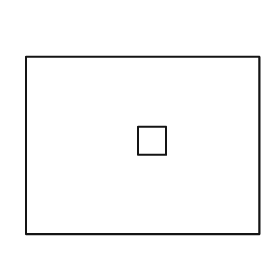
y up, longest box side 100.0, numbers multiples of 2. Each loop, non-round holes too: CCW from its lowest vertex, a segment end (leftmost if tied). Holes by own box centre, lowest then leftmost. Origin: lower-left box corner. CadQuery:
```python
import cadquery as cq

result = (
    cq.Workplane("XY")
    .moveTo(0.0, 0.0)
    .lineTo(100.0, 0.0)
    .lineTo(100.0, 76.0)
    .lineTo(0.0, 76.0)
    .close()
    .moveTo(48.0, 34.0)
    .lineTo(60.0, 34.0)
    .lineTo(60.0, 46.0)
    .lineTo(48.0, 46.0)
    .close()
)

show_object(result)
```